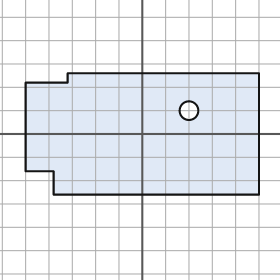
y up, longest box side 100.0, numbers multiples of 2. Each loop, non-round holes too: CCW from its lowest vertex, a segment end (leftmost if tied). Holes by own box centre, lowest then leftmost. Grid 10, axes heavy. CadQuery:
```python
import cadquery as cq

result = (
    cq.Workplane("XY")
    .moveTo(-38.0, -26.0)
    .lineTo(50.0, -26.0)
    .lineTo(50.0, 26.0)
    .lineTo(-32.0, 26.0)
    .lineTo(-32.0, 22.0)
    .lineTo(-50.0, 22.0)
    .lineTo(-50.0, -16.0)
    .lineTo(-38.0, -16.0)
    .close()
    .moveTo(20.0, 10.0)
    .circle(4.0)
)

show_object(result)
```